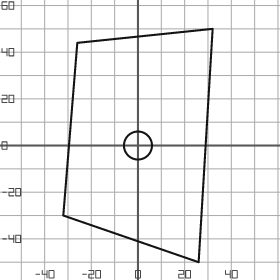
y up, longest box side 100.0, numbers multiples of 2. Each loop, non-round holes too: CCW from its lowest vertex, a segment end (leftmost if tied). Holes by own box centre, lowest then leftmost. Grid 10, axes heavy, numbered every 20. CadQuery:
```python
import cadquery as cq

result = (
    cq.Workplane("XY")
    .moveTo(26.0, -50.0)
    .lineTo(32.0, 50.0)
    .lineTo(-26.0, 44.0)
    .lineTo(-32.0, -30.0)
    .close()
    .moveTo(0.0, 0.0)
    .circle(6.0)
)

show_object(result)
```